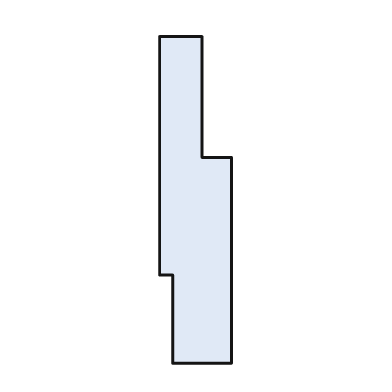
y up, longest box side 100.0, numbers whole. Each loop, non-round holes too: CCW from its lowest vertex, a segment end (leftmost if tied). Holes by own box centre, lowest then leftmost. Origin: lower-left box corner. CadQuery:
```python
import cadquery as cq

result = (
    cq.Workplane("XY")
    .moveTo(4.0, 0.0)
    .lineTo(22.0, 0.0)
    .lineTo(22.0, 63.0)
    .lineTo(13.0, 63.0)
    .lineTo(13.0, 100.0)
    .lineTo(0.0, 100.0)
    .lineTo(0.0, 27.0)
    .lineTo(4.0, 27.0)
    .close()
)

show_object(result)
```